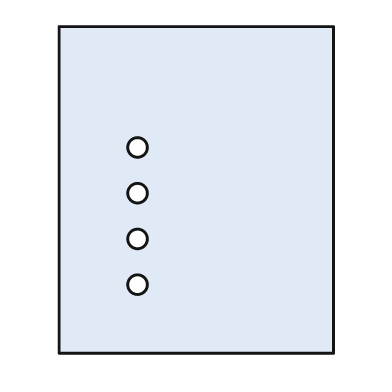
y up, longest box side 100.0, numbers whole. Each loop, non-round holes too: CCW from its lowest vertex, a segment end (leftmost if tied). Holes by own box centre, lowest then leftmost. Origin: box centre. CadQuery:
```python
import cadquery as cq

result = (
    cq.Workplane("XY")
    .moveTo(-42.0, -50.0)
    .lineTo(42.0, -50.0)
    .lineTo(42.0, 50.0)
    .lineTo(-42.0, 50.0)
    .close()
    .moveTo(-18.0, -29.0)
    .circle(3.0)
    .moveTo(-18.0, -15.0)
    .circle(3.0)
    .moveTo(-18.0, -1.0)
    .circle(3.0)
    .moveTo(-18.0, 13.0)
    .circle(3.0)
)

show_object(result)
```